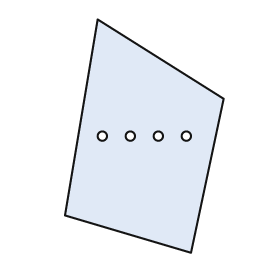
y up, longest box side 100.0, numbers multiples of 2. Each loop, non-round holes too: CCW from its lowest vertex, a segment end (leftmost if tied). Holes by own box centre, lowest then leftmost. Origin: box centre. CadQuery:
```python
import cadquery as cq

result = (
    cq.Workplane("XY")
    .moveTo(20.0, -50.0)
    .lineTo(34.0, 16.0)
    .lineTo(-20.0, 50.0)
    .lineTo(-34.0, -34.0)
    .close()
    .moveTo(-18.0, 0.0)
    .circle(2.0)
    .moveTo(-6.0, 0.0)
    .circle(2.0)
    .moveTo(6.0, 0.0)
    .circle(2.0)
    .moveTo(18.0, 0.0)
    .circle(2.0)
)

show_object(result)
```